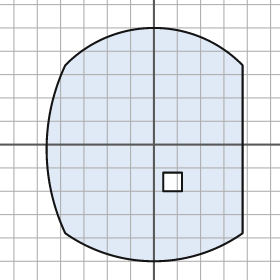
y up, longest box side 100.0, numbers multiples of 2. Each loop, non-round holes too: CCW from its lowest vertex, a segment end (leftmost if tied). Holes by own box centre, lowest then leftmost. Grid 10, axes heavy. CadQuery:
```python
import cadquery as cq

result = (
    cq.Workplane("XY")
    .moveTo(-38.0, -38.0)
    .threePointArc((0.0, -50.0), (38.0, -38.0))
    .lineTo(38.0, 34.0)
    .threePointArc((0.0, 50.0), (-38.0, 34.0))
    .threePointArc((-46.0, -2.0), (-38.0, -38.0))
    .close()
    .moveTo(4.0, -20.0)
    .lineTo(12.0, -20.0)
    .lineTo(12.0, -12.0)
    .lineTo(4.0, -12.0)
    .close()
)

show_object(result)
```